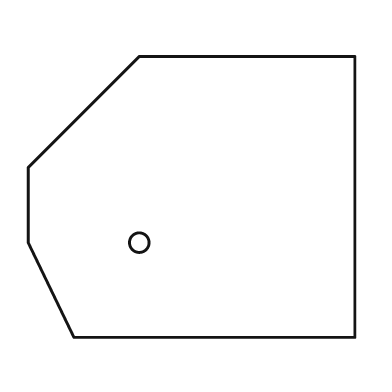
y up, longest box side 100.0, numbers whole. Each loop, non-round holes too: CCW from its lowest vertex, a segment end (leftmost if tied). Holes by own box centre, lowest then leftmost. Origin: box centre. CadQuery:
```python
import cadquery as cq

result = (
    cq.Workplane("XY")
    .moveTo(-36.0, -43.0)
    .lineTo(50.0, -43.0)
    .lineTo(50.0, 43.0)
    .lineTo(-16.0, 43.0)
    .lineTo(-50.0, 9.0)
    .lineTo(-50.0, -14.0)
    .close()
    .moveTo(-16.0, -14.0)
    .circle(3.0)
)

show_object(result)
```